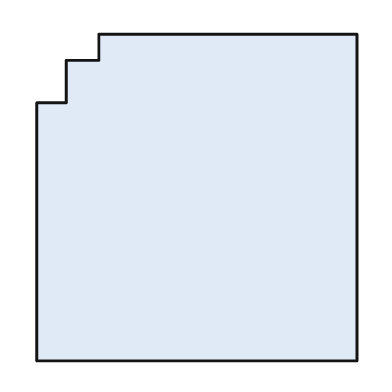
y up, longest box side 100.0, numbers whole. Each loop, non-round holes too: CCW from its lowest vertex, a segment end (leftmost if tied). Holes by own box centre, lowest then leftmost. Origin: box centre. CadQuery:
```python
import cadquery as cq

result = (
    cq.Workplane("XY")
    .moveTo(-49.0, -50.0)
    .lineTo(49.0, -50.0)
    .lineTo(49.0, 50.0)
    .lineTo(-30.0, 50.0)
    .lineTo(-30.0, 42.0)
    .lineTo(-40.0, 42.0)
    .lineTo(-40.0, 29.0)
    .lineTo(-49.0, 29.0)
    .close()
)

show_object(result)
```